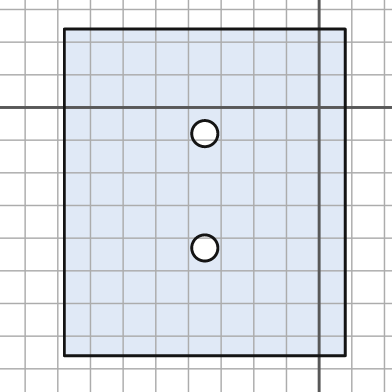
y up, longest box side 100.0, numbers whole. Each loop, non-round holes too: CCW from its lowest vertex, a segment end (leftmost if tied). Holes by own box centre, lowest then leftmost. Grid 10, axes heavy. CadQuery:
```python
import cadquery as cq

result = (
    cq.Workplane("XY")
    .moveTo(-78.0, -76.0)
    .lineTo(8.0, -76.0)
    .lineTo(8.0, 24.0)
    .lineTo(-78.0, 24.0)
    .close()
    .moveTo(-35.0, -43.0)
    .circle(4.0)
    .moveTo(-35.0, -8.0)
    .circle(4.0)
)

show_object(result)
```